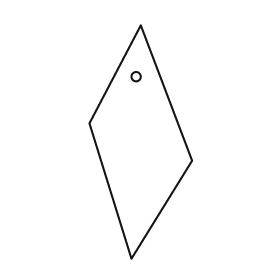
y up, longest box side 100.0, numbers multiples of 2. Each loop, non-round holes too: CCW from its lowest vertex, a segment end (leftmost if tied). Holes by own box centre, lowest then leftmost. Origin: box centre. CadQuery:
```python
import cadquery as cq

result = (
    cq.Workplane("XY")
    .moveTo(-4.0, -50.0)
    .lineTo(22.0, -8.0)
    .lineTo(0.0, 50.0)
    .lineTo(-22.0, 8.0)
    .close()
    .moveTo(-2.0, 28.0)
    .circle(2.0)
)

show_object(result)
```